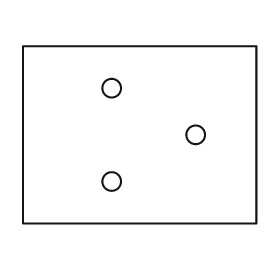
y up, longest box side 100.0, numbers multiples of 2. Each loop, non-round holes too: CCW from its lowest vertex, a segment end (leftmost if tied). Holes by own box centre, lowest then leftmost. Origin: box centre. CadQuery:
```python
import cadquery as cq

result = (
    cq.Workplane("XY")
    .moveTo(-50.0, -38.0)
    .lineTo(50.0, -38.0)
    .lineTo(50.0, 38.0)
    .lineTo(-50.0, 38.0)
    .close()
    .moveTo(-12.0, -20.0)
    .circle(4.0)
    .moveTo(24.0, 0.0)
    .circle(4.0)
    .moveTo(-12.0, 20.0)
    .circle(4.0)
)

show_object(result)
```